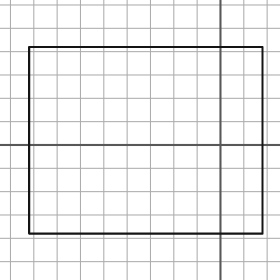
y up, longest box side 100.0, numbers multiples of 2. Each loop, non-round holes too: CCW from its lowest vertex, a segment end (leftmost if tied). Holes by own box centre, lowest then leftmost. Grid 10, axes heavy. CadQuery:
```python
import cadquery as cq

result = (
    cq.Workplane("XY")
    .moveTo(-82.0, -38.0)
    .lineTo(18.0, -38.0)
    .lineTo(18.0, 42.0)
    .lineTo(-82.0, 42.0)
    .close()
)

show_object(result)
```